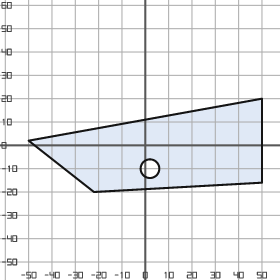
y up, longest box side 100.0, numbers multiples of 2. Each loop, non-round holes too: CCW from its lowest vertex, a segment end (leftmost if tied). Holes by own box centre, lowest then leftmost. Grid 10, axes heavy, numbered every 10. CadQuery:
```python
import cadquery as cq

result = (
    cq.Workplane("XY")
    .moveTo(-22.0, -20.0)
    .lineTo(50.0, -16.0)
    .lineTo(50.0, 20.0)
    .lineTo(-50.0, 2.0)
    .close()
    .moveTo(2.0, -10.0)
    .circle(4.0)
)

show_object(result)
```